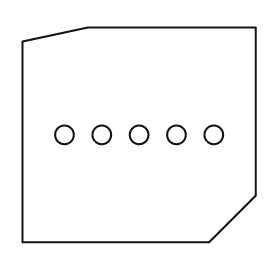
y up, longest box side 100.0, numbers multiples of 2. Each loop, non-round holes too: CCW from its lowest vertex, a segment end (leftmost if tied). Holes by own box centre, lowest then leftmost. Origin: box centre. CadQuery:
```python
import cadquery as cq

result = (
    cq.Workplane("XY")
    .moveTo(-50.0, -46.0)
    .lineTo(30.0, -46.0)
    .lineTo(50.0, -26.0)
    .lineTo(50.0, 46.0)
    .lineTo(-22.0, 46.0)
    .lineTo(-50.0, 40.0)
    .close()
    .moveTo(-32.0, 0.0)
    .circle(4.0)
    .moveTo(-16.0, 0.0)
    .circle(4.0)
    .moveTo(0.0, 0.0)
    .circle(4.0)
    .moveTo(16.0, 0.0)
    .circle(4.0)
    .moveTo(32.0, 0.0)
    .circle(4.0)
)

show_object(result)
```